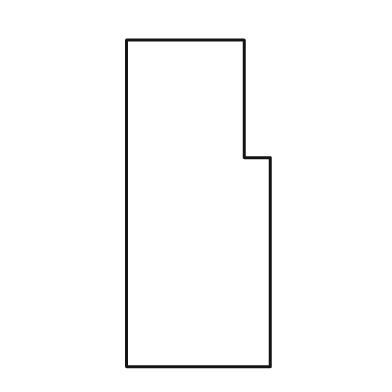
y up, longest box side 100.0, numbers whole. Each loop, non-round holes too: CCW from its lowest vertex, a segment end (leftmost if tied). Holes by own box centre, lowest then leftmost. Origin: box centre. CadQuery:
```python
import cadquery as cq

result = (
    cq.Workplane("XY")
    .moveTo(-22.0, -50.0)
    .lineTo(22.0, -50.0)
    .lineTo(22.0, 14.0)
    .lineTo(14.0, 14.0)
    .lineTo(14.0, 50.0)
    .lineTo(-22.0, 50.0)
    .close()
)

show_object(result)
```